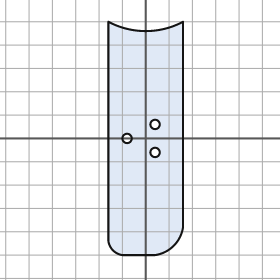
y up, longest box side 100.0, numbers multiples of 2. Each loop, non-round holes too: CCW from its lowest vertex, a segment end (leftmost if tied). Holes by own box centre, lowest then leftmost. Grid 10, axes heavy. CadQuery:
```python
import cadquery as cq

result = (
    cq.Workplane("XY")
    .moveTo(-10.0, -50.0)
    .lineTo(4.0, -50.0)
    .threePointArc((12.0, -46.0), (16.0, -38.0))
    .lineTo(16.0, 50.0)
    .threePointArc((0.0, 46.0), (-16.0, 50.0))
    .lineTo(-16.0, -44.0)
    .threePointArc((-14.0, -48.0), (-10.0, -50.0))
    .close()
    .moveTo(4.0, -6.0)
    .circle(2.0)
    .moveTo(-8.0, 0.0)
    .circle(2.0)
    .moveTo(4.0, 6.0)
    .circle(2.0)
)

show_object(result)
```